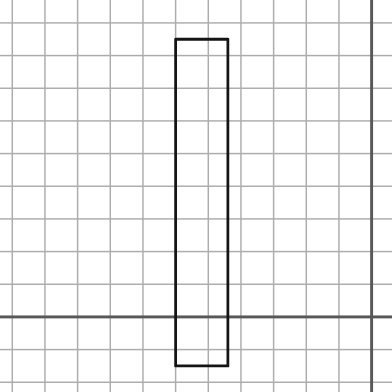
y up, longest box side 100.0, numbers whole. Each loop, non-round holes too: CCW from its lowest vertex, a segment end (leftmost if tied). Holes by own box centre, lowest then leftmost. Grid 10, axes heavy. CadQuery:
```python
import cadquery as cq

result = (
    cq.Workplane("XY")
    .moveTo(-60.0, -15.0)
    .lineTo(-44.0, -15.0)
    .lineTo(-44.0, 85.0)
    .lineTo(-60.0, 85.0)
    .close()
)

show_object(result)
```